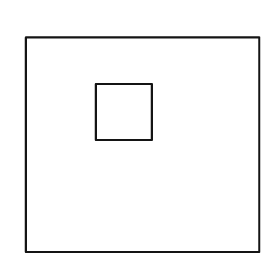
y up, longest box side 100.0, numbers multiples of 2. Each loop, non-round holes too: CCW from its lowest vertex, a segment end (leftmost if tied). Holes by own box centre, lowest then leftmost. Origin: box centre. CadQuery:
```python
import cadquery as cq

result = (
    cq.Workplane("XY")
    .moveTo(-50.0, -46.0)
    .lineTo(50.0, -46.0)
    .lineTo(50.0, 46.0)
    .lineTo(-50.0, 46.0)
    .close()
    .moveTo(-20.0, 2.0)
    .lineTo(4.0, 2.0)
    .lineTo(4.0, 26.0)
    .lineTo(-20.0, 26.0)
    .close()
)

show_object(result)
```